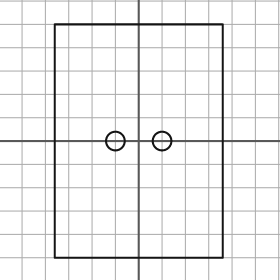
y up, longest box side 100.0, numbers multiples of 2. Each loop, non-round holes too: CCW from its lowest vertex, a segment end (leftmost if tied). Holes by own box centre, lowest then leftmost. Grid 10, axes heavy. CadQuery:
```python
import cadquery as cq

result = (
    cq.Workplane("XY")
    .moveTo(-36.0, -50.0)
    .lineTo(36.0, -50.0)
    .lineTo(36.0, 50.0)
    .lineTo(-36.0, 50.0)
    .close()
    .moveTo(-10.0, 0.0)
    .circle(4.0)
    .moveTo(10.0, 0.0)
    .circle(4.0)
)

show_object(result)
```